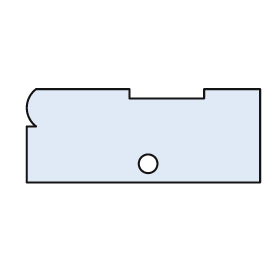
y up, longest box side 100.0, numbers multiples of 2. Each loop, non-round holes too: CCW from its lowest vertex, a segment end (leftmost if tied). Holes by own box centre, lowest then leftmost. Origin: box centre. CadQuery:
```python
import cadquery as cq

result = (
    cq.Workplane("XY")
    .moveTo(-50.0, -20.0)
    .lineTo(50.0, -20.0)
    .lineTo(50.0, 20.0)
    .lineTo(26.0, 20.0)
    .lineTo(26.0, 16.0)
    .lineTo(-6.0, 16.0)
    .lineTo(-6.0, 20.0)
    .lineTo(-46.0, 20.0)
    .threePointArc((-50.0, 12.0), (-46.0, 4.0))
    .lineTo(-50.0, 4.0)
    .close()
    .moveTo(2.0, -12.0)
    .circle(4.0)
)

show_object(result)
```